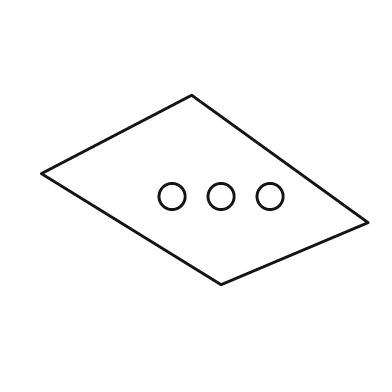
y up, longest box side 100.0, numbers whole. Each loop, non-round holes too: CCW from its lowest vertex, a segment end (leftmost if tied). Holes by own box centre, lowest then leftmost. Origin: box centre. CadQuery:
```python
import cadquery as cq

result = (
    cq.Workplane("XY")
    .moveTo(5.0, -29.0)
    .lineTo(50.0, -10.0)
    .lineTo(-4.0, 29.0)
    .lineTo(-50.0, 5.0)
    .close()
    .moveTo(-10.0, -2.0)
    .circle(4.0)
    .moveTo(5.0, -2.0)
    .circle(4.0)
    .moveTo(20.0, -2.0)
    .circle(4.0)
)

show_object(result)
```